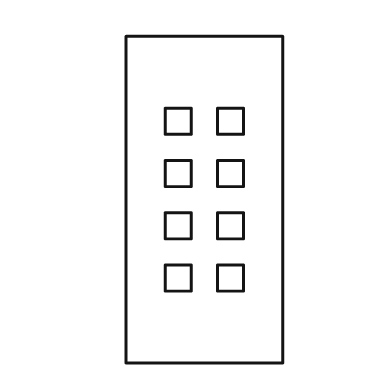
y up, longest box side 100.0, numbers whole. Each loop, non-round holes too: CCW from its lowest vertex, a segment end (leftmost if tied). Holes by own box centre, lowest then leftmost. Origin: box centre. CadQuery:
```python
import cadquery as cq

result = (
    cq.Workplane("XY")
    .moveTo(-24.0, -50.0)
    .lineTo(24.0, -50.0)
    .lineTo(24.0, 50.0)
    .lineTo(-24.0, 50.0)
    .close()
    .moveTo(-12.0, -28.0)
    .lineTo(-4.0, -28.0)
    .lineTo(-4.0, -20.0)
    .lineTo(-12.0, -20.0)
    .close()
    .moveTo(4.0, -28.0)
    .lineTo(12.0, -28.0)
    .lineTo(12.0, -20.0)
    .lineTo(4.0, -20.0)
    .close()
    .moveTo(-12.0, -12.0)
    .lineTo(-4.0, -12.0)
    .lineTo(-4.0, -4.0)
    .lineTo(-12.0, -4.0)
    .close()
    .moveTo(4.0, -12.0)
    .lineTo(12.0, -12.0)
    .lineTo(12.0, -4.0)
    .lineTo(4.0, -4.0)
    .close()
    .moveTo(-12.0, 4.0)
    .lineTo(-4.0, 4.0)
    .lineTo(-4.0, 12.0)
    .lineTo(-12.0, 12.0)
    .close()
    .moveTo(4.0, 4.0)
    .lineTo(12.0, 4.0)
    .lineTo(12.0, 12.0)
    .lineTo(4.0, 12.0)
    .close()
    .moveTo(-12.0, 20.0)
    .lineTo(-4.0, 20.0)
    .lineTo(-4.0, 28.0)
    .lineTo(-12.0, 28.0)
    .close()
    .moveTo(4.0, 20.0)
    .lineTo(12.0, 20.0)
    .lineTo(12.0, 28.0)
    .lineTo(4.0, 28.0)
    .close()
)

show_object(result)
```